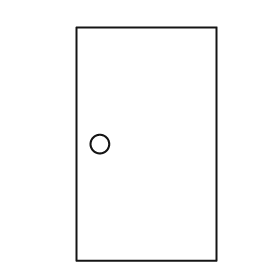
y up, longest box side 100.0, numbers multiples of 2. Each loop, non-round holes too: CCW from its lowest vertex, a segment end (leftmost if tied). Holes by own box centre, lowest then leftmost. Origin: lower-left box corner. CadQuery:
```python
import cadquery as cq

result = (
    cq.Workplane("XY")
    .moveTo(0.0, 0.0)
    .lineTo(60.0, 0.0)
    .lineTo(60.0, 100.0)
    .lineTo(0.0, 100.0)
    .close()
    .moveTo(10.0, 50.0)
    .circle(4.0)
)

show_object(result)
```